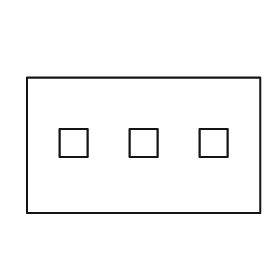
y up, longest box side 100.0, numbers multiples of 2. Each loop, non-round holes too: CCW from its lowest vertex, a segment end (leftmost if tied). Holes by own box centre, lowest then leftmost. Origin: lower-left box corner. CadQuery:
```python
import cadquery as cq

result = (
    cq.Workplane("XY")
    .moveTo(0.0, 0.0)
    .lineTo(100.0, 0.0)
    .lineTo(100.0, 58.0)
    .lineTo(0.0, 58.0)
    .close()
    .moveTo(14.0, 24.0)
    .lineTo(26.0, 24.0)
    .lineTo(26.0, 36.0)
    .lineTo(14.0, 36.0)
    .close()
    .moveTo(44.0, 24.0)
    .lineTo(56.0, 24.0)
    .lineTo(56.0, 36.0)
    .lineTo(44.0, 36.0)
    .close()
    .moveTo(74.0, 24.0)
    .lineTo(86.0, 24.0)
    .lineTo(86.0, 36.0)
    .lineTo(74.0, 36.0)
    .close()
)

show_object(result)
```